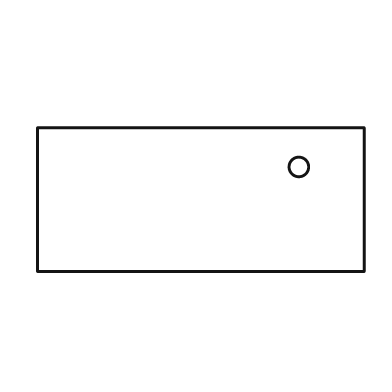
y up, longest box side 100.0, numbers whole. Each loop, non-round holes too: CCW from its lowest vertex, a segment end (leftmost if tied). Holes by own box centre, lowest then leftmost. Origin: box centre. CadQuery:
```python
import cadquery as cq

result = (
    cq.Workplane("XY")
    .moveTo(-50.0, -22.0)
    .lineTo(50.0, -22.0)
    .lineTo(50.0, 22.0)
    .lineTo(-50.0, 22.0)
    .close()
    .moveTo(30.0, 10.0)
    .circle(3.0)
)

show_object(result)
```